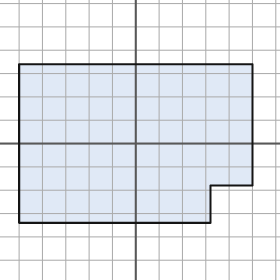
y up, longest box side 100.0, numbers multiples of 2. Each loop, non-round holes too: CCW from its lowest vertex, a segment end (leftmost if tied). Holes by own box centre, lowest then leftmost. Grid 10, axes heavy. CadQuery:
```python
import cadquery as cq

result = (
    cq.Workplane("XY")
    .moveTo(-50.0, -34.0)
    .lineTo(32.0, -34.0)
    .lineTo(32.0, -18.0)
    .lineTo(50.0, -18.0)
    .lineTo(50.0, 34.0)
    .lineTo(-50.0, 34.0)
    .close()
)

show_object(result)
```